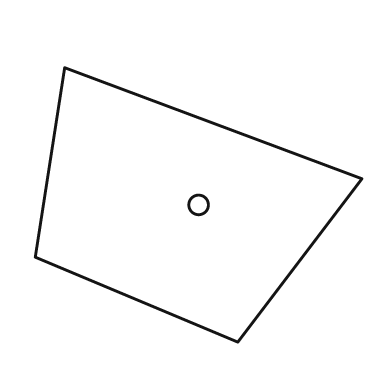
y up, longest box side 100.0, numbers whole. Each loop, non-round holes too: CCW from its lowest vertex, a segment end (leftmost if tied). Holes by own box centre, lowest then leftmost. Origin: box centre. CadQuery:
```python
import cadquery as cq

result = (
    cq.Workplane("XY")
    .moveTo(12.0, -42.0)
    .lineTo(50.0, 8.0)
    .lineTo(-41.0, 42.0)
    .lineTo(-50.0, -16.0)
    .close()
    .moveTo(0.0, 0.0)
    .circle(3.0)
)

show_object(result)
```